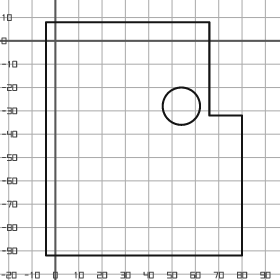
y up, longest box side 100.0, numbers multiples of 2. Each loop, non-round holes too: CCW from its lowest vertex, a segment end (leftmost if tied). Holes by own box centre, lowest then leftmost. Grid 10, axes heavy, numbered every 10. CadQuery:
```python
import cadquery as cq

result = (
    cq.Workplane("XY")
    .moveTo(-4.0, -92.0)
    .lineTo(80.0, -92.0)
    .lineTo(80.0, -32.0)
    .lineTo(66.0, -32.0)
    .lineTo(66.0, 8.0)
    .lineTo(-4.0, 8.0)
    .close()
    .moveTo(54.0, -28.0)
    .circle(8.0)
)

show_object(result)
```